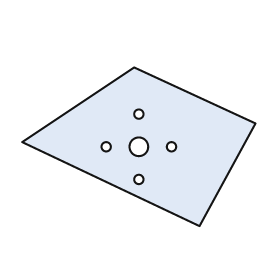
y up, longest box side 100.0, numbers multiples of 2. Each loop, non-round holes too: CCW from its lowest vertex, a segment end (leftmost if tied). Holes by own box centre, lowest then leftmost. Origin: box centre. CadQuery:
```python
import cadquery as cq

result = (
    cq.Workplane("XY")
    .moveTo(26.0, -34.0)
    .lineTo(50.0, 10.0)
    .lineTo(-2.0, 34.0)
    .lineTo(-50.0, 2.0)
    .close()
    .moveTo(0.0, -14.0)
    .circle(2.0)
    .moveTo(-14.0, 0.0)
    .circle(2.0)
    .moveTo(0.0, 0.0)
    .circle(4.0)
    .moveTo(14.0, 0.0)
    .circle(2.0)
    .moveTo(0.0, 14.0)
    .circle(2.0)
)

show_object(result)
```